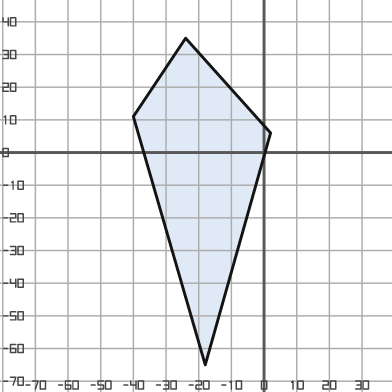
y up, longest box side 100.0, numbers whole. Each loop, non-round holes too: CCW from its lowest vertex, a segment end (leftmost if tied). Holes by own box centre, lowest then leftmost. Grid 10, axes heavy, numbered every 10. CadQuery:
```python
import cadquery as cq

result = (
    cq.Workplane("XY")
    .moveTo(-18.0, -65.0)
    .lineTo(2.0, 6.0)
    .lineTo(-24.0, 35.0)
    .lineTo(-40.0, 11.0)
    .close()
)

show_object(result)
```